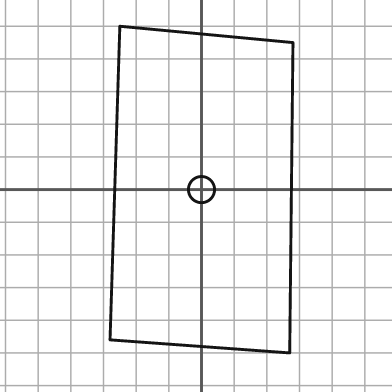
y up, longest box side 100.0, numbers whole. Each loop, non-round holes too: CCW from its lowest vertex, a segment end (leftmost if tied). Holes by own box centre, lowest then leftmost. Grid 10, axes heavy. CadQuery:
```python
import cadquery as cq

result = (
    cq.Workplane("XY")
    .moveTo(27.0, -50.0)
    .lineTo(28.0, 45.0)
    .lineTo(-25.0, 50.0)
    .lineTo(-28.0, -46.0)
    .close()
    .moveTo(0.0, 0.0)
    .circle(4.0)
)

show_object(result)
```